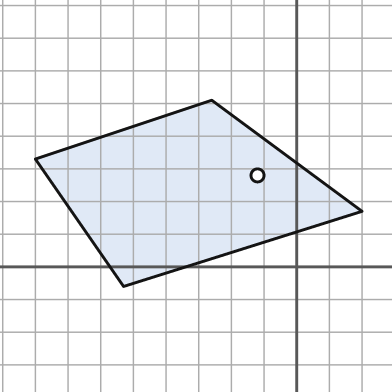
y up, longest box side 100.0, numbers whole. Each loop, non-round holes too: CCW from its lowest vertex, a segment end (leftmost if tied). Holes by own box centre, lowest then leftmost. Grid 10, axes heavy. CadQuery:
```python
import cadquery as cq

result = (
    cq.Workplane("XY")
    .moveTo(-53.0, -6.0)
    .lineTo(20.0, 17.0)
    .lineTo(-26.0, 51.0)
    .lineTo(-80.0, 33.0)
    .close()
    .moveTo(-12.0, 28.0)
    .circle(2.0)
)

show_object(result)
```